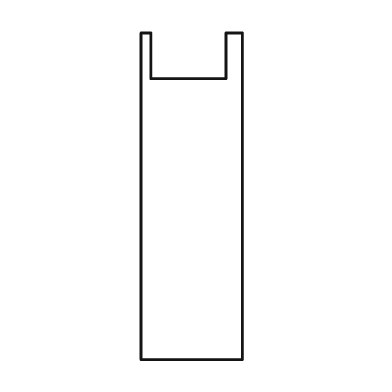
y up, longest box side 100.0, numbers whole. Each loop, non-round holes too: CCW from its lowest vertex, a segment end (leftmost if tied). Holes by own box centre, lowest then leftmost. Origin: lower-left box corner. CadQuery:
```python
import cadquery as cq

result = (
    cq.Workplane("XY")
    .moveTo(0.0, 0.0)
    .lineTo(31.0, 0.0)
    .lineTo(31.0, 100.0)
    .lineTo(26.0, 100.0)
    .lineTo(26.0, 86.0)
    .lineTo(3.0, 86.0)
    .lineTo(3.0, 100.0)
    .lineTo(0.0, 100.0)
    .close()
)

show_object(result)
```